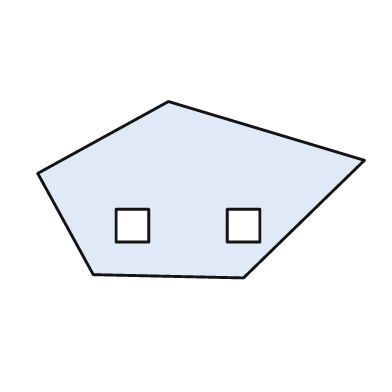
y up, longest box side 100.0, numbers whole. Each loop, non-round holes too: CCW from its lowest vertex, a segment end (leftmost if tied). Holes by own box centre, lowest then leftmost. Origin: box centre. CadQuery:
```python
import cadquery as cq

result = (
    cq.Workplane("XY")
    .moveTo(13.0, -27.0)
    .lineTo(50.0, 9.0)
    .lineTo(-10.0, 27.0)
    .lineTo(-50.0, 5.0)
    .lineTo(-33.0, -26.0)
    .close()
    .moveTo(-26.0, -16.0)
    .lineTo(-16.0, -16.0)
    .lineTo(-16.0, -6.0)
    .lineTo(-26.0, -6.0)
    .close()
    .moveTo(8.0, -16.0)
    .lineTo(18.0, -16.0)
    .lineTo(18.0, -6.0)
    .lineTo(8.0, -6.0)
    .close()
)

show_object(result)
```